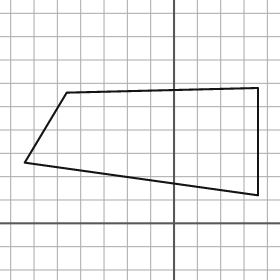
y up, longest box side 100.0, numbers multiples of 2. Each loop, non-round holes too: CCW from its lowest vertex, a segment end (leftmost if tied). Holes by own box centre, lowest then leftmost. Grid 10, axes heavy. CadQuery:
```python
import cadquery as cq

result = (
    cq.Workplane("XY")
    .moveTo(36.0, 12.0)
    .lineTo(36.0, 58.0)
    .lineTo(-46.0, 56.0)
    .lineTo(-64.0, 26.0)
    .close()
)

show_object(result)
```